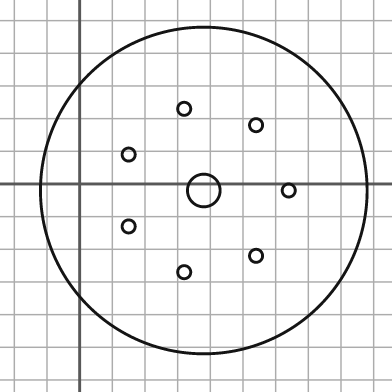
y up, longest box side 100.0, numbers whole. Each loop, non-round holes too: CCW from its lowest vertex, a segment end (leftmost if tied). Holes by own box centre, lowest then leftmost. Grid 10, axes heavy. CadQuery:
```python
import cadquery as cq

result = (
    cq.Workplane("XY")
    .moveTo(38.0, -2.0)
    .circle(50.0)
    .moveTo(32.0, -27.0)
    .circle(2.0)
    .moveTo(54.0, -22.0)
    .circle(2.0)
    .moveTo(15.0, -13.0)
    .circle(2.0)
    .moveTo(38.0, -2.0)
    .circle(5.0)
    .moveTo(64.0, -2.0)
    .circle(2.0)
    .moveTo(15.0, 9.0)
    .circle(2.0)
    .moveTo(54.0, 18.0)
    .circle(2.0)
    .moveTo(32.0, 23.0)
    .circle(2.0)
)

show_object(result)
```